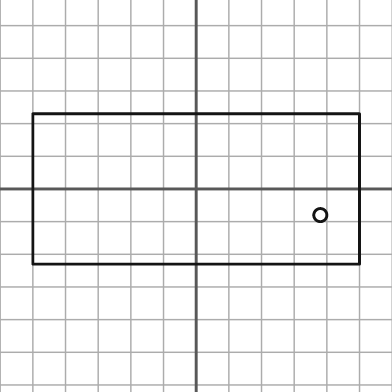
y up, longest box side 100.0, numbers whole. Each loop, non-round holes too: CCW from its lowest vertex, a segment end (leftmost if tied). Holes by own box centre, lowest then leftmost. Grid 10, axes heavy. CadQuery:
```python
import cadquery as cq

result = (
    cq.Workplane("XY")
    .moveTo(-50.0, -23.0)
    .lineTo(50.0, -23.0)
    .lineTo(50.0, 23.0)
    .lineTo(-50.0, 23.0)
    .close()
    .moveTo(38.0, -8.0)
    .circle(2.0)
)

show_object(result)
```